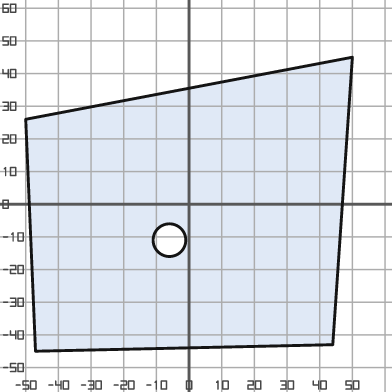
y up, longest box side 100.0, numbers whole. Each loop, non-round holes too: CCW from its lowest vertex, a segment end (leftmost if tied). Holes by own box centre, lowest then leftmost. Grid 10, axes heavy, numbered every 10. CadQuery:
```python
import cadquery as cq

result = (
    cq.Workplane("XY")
    .moveTo(-47.0, -45.0)
    .lineTo(44.0, -43.0)
    .lineTo(50.0, 45.0)
    .lineTo(-50.0, 26.0)
    .close()
    .moveTo(-6.0, -11.0)
    .circle(5.0)
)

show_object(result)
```